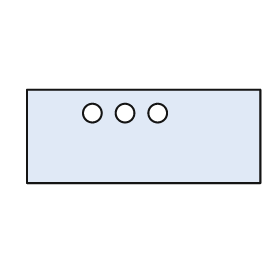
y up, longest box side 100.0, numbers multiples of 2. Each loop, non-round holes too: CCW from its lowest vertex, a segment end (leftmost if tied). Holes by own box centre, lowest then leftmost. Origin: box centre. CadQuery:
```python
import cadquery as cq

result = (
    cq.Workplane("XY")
    .moveTo(-50.0, -20.0)
    .lineTo(50.0, -20.0)
    .lineTo(50.0, 20.0)
    .lineTo(-50.0, 20.0)
    .close()
    .moveTo(-22.0, 10.0)
    .circle(4.0)
    .moveTo(-8.0, 10.0)
    .circle(4.0)
    .moveTo(6.0, 10.0)
    .circle(4.0)
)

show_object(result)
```